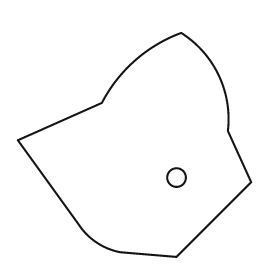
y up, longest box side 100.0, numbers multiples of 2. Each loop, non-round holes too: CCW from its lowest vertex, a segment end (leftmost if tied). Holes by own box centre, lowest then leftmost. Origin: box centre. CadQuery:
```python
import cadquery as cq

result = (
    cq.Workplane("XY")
    .moveTo(18.0, -48.0)
    .lineTo(50.0, -16.0)
    .lineTo(40.0, 6.0)
    .threePointArc((36.0, 30.0), (20.0, 48.0))
    .threePointArc((0.0, 36.0), (-14.0, 18.0))
    .lineTo(-50.0, 2.0)
    .lineTo(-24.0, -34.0)
    .threePointArc((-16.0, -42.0), (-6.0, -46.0))
    .close()
    .moveTo(18.0, -14.0)
    .circle(4.0)
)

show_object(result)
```